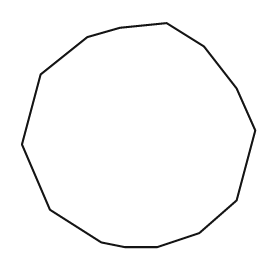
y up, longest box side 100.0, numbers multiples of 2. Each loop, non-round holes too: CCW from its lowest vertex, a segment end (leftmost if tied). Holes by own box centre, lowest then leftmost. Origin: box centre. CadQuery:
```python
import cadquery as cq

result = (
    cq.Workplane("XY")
    .moveTo(-6.0, -48.0)
    .lineTo(8.0, -48.0)
    .lineTo(26.0, -42.0)
    .lineTo(42.0, -28.0)
    .lineTo(50.0, 2.0)
    .lineTo(42.0, 20.0)
    .lineTo(28.0, 38.0)
    .lineTo(12.0, 48.0)
    .lineTo(-8.0, 46.0)
    .lineTo(-22.0, 42.0)
    .lineTo(-42.0, 26.0)
    .lineTo(-50.0, -4.0)
    .lineTo(-38.0, -32.0)
    .lineTo(-16.0, -46.0)
    .close()
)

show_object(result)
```